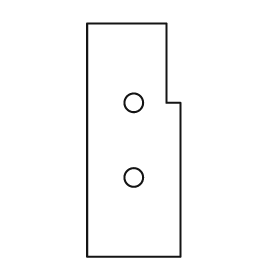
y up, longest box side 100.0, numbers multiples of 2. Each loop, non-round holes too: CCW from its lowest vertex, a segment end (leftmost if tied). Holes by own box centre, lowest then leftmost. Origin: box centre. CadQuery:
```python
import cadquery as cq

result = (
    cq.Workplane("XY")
    .moveTo(-20.0, -50.0)
    .lineTo(20.0, -50.0)
    .lineTo(20.0, 16.0)
    .lineTo(14.0, 16.0)
    .lineTo(14.0, 50.0)
    .lineTo(-20.0, 50.0)
    .close()
    .moveTo(0.0, -16.0)
    .circle(4.0)
    .moveTo(0.0, 16.0)
    .circle(4.0)
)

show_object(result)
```